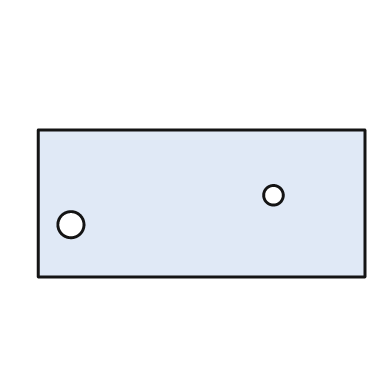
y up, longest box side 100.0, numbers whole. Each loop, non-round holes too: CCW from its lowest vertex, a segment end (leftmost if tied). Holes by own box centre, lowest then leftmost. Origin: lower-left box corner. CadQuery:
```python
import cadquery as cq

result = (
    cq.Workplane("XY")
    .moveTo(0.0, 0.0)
    .lineTo(100.0, 0.0)
    .lineTo(100.0, 45.0)
    .lineTo(0.0, 45.0)
    .close()
    .moveTo(10.0, 16.0)
    .circle(4.0)
    .moveTo(72.0, 25.0)
    .circle(3.0)
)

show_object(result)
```